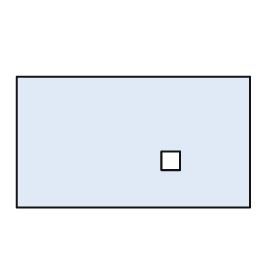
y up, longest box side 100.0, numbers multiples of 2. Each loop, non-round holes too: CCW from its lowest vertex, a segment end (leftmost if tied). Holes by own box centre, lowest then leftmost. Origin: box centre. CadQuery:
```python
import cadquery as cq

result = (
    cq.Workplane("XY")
    .moveTo(-50.0, -28.0)
    .lineTo(50.0, -28.0)
    .lineTo(50.0, 28.0)
    .lineTo(-50.0, 28.0)
    .close()
    .moveTo(12.0, -12.0)
    .lineTo(20.0, -12.0)
    .lineTo(20.0, -4.0)
    .lineTo(12.0, -4.0)
    .close()
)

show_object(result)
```